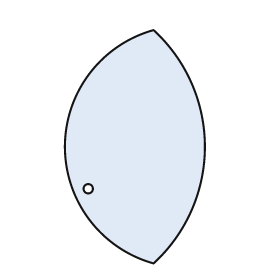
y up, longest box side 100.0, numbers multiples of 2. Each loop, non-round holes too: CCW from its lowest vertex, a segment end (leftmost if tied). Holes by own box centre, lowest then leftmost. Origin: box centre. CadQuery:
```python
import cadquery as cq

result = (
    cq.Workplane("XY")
    .moveTo(8.0, -50.0)
    .threePointArc((30.0, 0.0), (8.0, 50.0))
    .threePointArc((-30.0, 0.0), (8.0, -50.0))
    .close()
    .moveTo(-20.0, -18.0)
    .circle(2.0)
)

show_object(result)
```